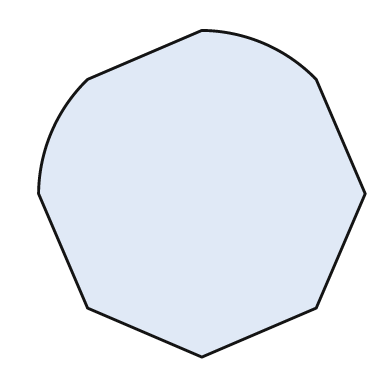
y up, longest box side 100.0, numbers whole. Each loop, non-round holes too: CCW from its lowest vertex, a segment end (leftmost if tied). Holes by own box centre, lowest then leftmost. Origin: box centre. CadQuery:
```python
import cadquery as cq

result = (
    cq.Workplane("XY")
    .moveTo(0.0, -50.0)
    .lineTo(35.0, -35.0)
    .lineTo(50.0, 0.0)
    .lineTo(35.0, 35.0)
    .threePointArc((19.0, 46.0), (0.0, 50.0))
    .lineTo(-35.0, 35.0)
    .threePointArc((-46.0, 19.0), (-50.0, 0.0))
    .lineTo(-35.0, -35.0)
    .close()
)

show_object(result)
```